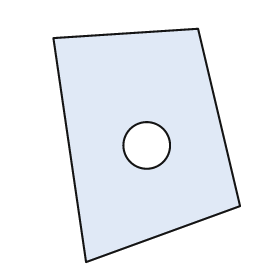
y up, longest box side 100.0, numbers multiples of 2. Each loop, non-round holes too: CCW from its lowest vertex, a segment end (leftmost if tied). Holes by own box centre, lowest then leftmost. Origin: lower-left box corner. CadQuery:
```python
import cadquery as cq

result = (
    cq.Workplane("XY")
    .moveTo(14.0, 0.0)
    .lineTo(80.0, 24.0)
    .lineTo(62.0, 100.0)
    .lineTo(0.0, 96.0)
    .close()
    .moveTo(40.0, 50.0)
    .circle(10.0)
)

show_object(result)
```